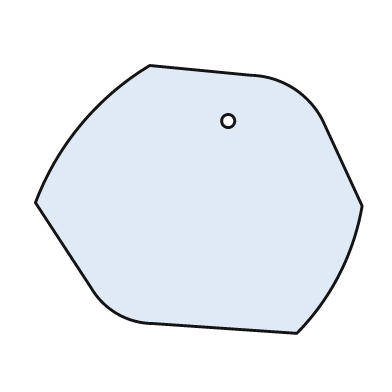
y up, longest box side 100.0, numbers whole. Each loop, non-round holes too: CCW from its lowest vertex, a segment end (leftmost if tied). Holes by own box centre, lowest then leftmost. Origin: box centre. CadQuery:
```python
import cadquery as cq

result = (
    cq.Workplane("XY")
    .moveTo(30.0, -41.0)
    .threePointArc((43.0, -23.0), (50.0, -2.0))
    .lineTo(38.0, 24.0)
    .threePointArc((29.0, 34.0), (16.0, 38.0))
    .lineTo(-15.0, 41.0)
    .threePointArc((-36.0, 23.0), (-50.0, -1.0))
    .lineTo(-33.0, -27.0)
    .threePointArc((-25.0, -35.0), (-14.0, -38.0))
    .close()
    .moveTo(9.0, 24.0)
    .circle(2.0)
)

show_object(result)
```